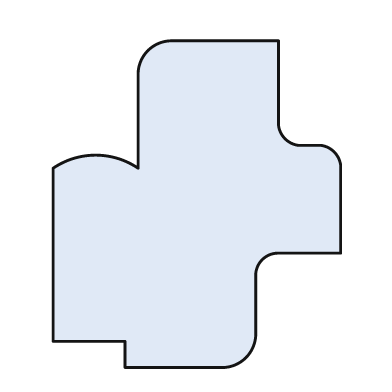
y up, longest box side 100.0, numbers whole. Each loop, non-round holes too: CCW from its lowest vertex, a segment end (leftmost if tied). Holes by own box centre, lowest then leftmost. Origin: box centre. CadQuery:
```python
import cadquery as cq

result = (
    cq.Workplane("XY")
    .moveTo(-22.0, -50.0)
    .lineTo(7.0, -50.0)
    .threePointArc((15.0, -47.0), (18.0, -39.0))
    .lineTo(18.0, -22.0)
    .threePointArc((20.0, -17.0), (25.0, -15.0))
    .lineTo(44.0, -15.0)
    .lineTo(44.0, 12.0)
    .threePointArc((42.0, 16.0), (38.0, 18.0))
    .lineTo(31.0, 18.0)
    .threePointArc((27.0, 20.0), (25.0, 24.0))
    .lineTo(25.0, 50.0)
    .lineTo(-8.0, 50.0)
    .threePointArc((-15.0, 47.0), (-18.0, 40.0))
    .lineTo(-18.0, 11.0)
    .threePointArc((-31.0, 15.0), (-44.0, 11.0))
    .lineTo(-44.0, -42.0)
    .lineTo(-22.0, -42.0)
    .close()
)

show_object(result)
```